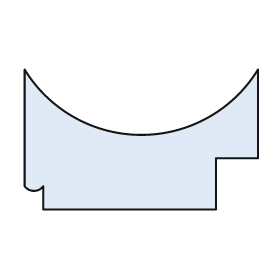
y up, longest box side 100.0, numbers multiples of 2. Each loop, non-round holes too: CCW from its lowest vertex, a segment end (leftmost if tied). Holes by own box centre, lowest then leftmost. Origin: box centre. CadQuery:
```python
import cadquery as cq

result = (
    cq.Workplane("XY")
    .moveTo(-42.0, -30.0)
    .lineTo(32.0, -30.0)
    .lineTo(32.0, -8.0)
    .lineTo(50.0, -8.0)
    .lineTo(50.0, 30.0)
    .threePointArc((0.0, 2.0), (-50.0, 30.0))
    .lineTo(-50.0, -20.0)
    .threePointArc((-46.0, -22.0), (-42.0, -20.0))
    .close()
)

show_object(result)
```